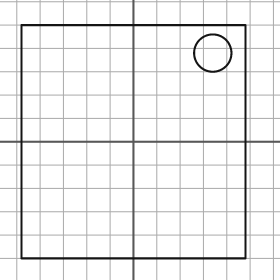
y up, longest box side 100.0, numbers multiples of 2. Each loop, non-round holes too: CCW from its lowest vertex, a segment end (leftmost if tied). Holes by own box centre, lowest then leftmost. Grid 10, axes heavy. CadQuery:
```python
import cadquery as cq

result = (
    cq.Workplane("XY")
    .moveTo(-48.0, -50.0)
    .lineTo(48.0, -50.0)
    .lineTo(48.0, 50.0)
    .lineTo(-48.0, 50.0)
    .close()
    .moveTo(34.0, 38.0)
    .circle(8.0)
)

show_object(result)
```